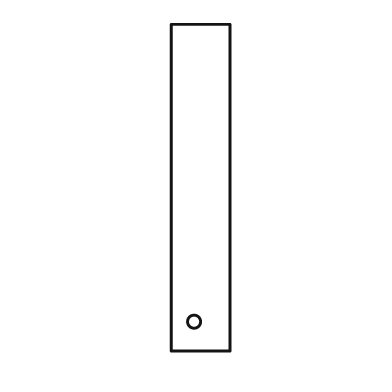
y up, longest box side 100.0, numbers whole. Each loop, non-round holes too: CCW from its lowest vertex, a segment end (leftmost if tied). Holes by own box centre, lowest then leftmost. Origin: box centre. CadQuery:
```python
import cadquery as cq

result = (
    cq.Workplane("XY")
    .moveTo(-9.0, -50.0)
    .lineTo(9.0, -50.0)
    .lineTo(9.0, 50.0)
    .lineTo(-9.0, 50.0)
    .close()
    .moveTo(-2.0, -41.0)
    .circle(2.0)
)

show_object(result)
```